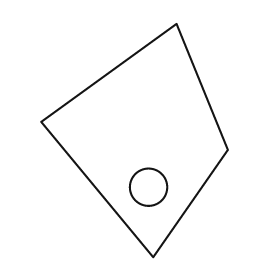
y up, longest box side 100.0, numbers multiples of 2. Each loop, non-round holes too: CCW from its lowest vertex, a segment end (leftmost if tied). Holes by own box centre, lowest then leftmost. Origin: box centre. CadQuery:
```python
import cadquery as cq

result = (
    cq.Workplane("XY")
    .moveTo(8.0, -50.0)
    .lineTo(40.0, -4.0)
    .lineTo(18.0, 50.0)
    .lineTo(-40.0, 8.0)
    .close()
    .moveTo(6.0, -20.0)
    .circle(8.0)
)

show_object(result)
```